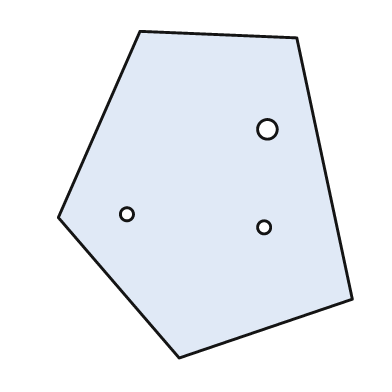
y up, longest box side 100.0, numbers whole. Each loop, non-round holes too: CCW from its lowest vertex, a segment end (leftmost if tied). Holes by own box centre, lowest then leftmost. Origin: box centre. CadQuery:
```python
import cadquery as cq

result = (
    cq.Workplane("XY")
    .moveTo(-8.0, -50.0)
    .lineTo(45.0, -32.0)
    .lineTo(28.0, 48.0)
    .lineTo(-20.0, 50.0)
    .lineTo(-45.0, -7.0)
    .close()
    .moveTo(18.0, -10.0)
    .circle(2.0)
    .moveTo(-24.0, -6.0)
    .circle(2.0)
    .moveTo(19.0, 20.0)
    .circle(3.0)
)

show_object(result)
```